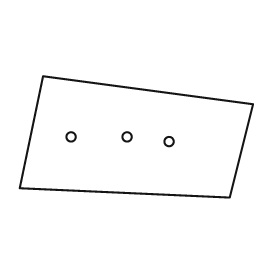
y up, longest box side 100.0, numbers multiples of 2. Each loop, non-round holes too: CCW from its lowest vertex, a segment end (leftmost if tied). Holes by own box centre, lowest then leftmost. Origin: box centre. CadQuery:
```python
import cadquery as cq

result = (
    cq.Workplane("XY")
    .moveTo(40.0, -26.0)
    .lineTo(50.0, 14.0)
    .lineTo(-40.0, 26.0)
    .lineTo(-50.0, -22.0)
    .close()
    .moveTo(14.0, -2.0)
    .circle(2.0)
    .moveTo(-28.0, 0.0)
    .circle(2.0)
    .moveTo(-4.0, 0.0)
    .circle(2.0)
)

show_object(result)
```